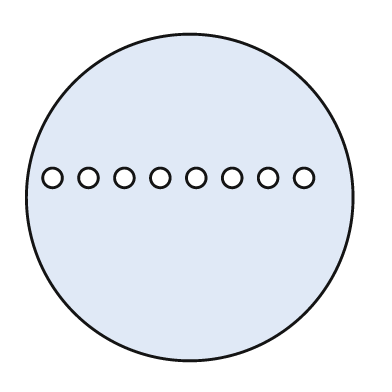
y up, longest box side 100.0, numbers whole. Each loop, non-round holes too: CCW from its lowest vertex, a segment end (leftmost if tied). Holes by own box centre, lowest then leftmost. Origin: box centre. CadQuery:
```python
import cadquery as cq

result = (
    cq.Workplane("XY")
    .moveTo(0.0, 0.0)
    .circle(50.0)
    .moveTo(-42.0, 6.0)
    .circle(3.0)
    .moveTo(-31.0, 6.0)
    .circle(3.0)
    .moveTo(-20.0, 6.0)
    .circle(3.0)
    .moveTo(-9.0, 6.0)
    .circle(3.0)
    .moveTo(2.0, 6.0)
    .circle(3.0)
    .moveTo(13.0, 6.0)
    .circle(3.0)
    .moveTo(24.0, 6.0)
    .circle(3.0)
    .moveTo(35.0, 6.0)
    .circle(3.0)
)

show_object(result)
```